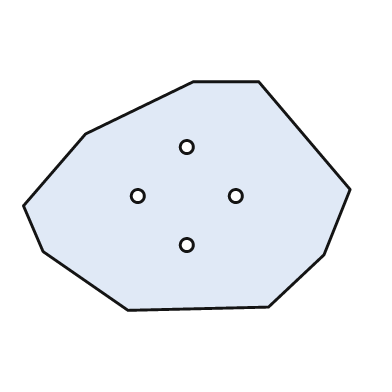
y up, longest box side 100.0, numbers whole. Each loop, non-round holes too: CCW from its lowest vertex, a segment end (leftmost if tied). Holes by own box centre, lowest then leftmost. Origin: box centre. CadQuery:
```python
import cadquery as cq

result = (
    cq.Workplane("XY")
    .moveTo(-18.0, -35.0)
    .lineTo(25.0, -34.0)
    .lineTo(42.0, -18.0)
    .lineTo(50.0, 2.0)
    .lineTo(22.0, 35.0)
    .lineTo(2.0, 35.0)
    .lineTo(-31.0, 19.0)
    .lineTo(-50.0, -3.0)
    .lineTo(-44.0, -17.0)
    .close()
    .moveTo(0.0, -15.0)
    .circle(2.0)
    .moveTo(-15.0, 0.0)
    .circle(2.0)
    .moveTo(15.0, 0.0)
    .circle(2.0)
    .moveTo(0.0, 15.0)
    .circle(2.0)
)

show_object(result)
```